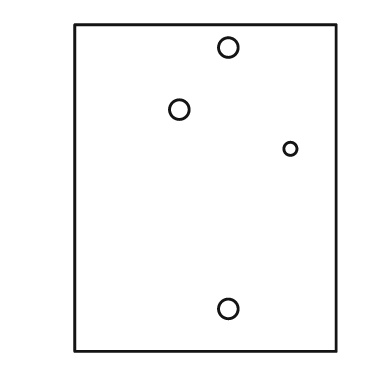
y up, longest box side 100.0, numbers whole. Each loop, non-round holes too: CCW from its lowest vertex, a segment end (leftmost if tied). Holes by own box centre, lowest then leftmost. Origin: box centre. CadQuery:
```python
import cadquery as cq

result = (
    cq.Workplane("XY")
    .moveTo(-40.0, -50.0)
    .lineTo(40.0, -50.0)
    .lineTo(40.0, 50.0)
    .lineTo(-40.0, 50.0)
    .close()
    .moveTo(7.0, -37.0)
    .circle(3.0)
    .moveTo(26.0, 12.0)
    .circle(2.0)
    .moveTo(-8.0, 24.0)
    .circle(3.0)
    .moveTo(7.0, 43.0)
    .circle(3.0)
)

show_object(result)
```